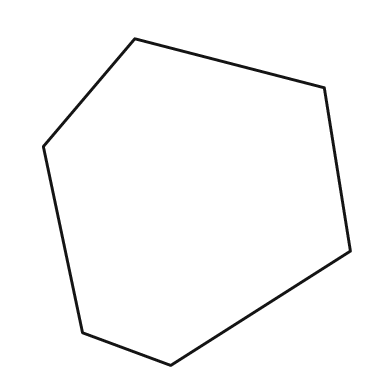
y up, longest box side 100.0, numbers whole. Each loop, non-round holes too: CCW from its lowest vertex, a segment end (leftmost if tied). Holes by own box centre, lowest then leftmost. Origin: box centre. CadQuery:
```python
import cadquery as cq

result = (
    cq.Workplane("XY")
    .moveTo(-8.0, -50.0)
    .lineTo(47.0, -15.0)
    .lineTo(39.0, 35.0)
    .lineTo(-19.0, 50.0)
    .lineTo(-47.0, 17.0)
    .lineTo(-35.0, -40.0)
    .close()
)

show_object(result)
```